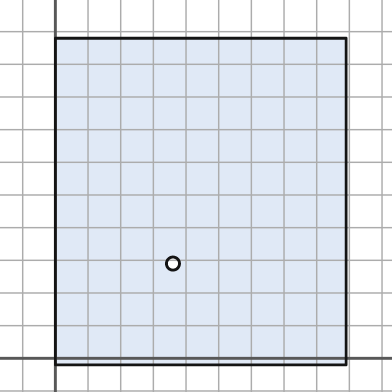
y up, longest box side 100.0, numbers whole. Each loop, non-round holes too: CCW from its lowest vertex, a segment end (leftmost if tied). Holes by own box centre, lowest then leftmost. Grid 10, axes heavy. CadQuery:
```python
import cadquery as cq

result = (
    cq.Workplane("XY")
    .moveTo(0.0, -2.0)
    .lineTo(89.0, -2.0)
    .lineTo(89.0, 98.0)
    .lineTo(0.0, 98.0)
    .close()
    .moveTo(36.0, 29.0)
    .circle(2.0)
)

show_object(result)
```